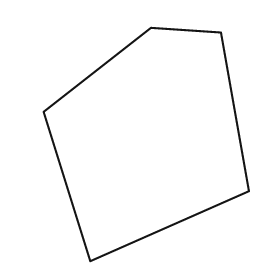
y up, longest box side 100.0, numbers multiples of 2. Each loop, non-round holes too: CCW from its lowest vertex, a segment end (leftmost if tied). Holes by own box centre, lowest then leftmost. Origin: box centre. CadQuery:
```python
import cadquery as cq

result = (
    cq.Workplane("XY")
    .moveTo(-24.0, -50.0)
    .lineTo(44.0, -20.0)
    .lineTo(32.0, 48.0)
    .lineTo(2.0, 50.0)
    .lineTo(-44.0, 14.0)
    .close()
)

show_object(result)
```